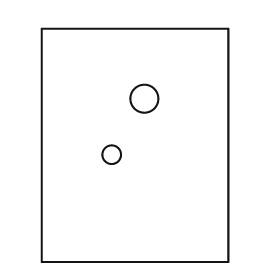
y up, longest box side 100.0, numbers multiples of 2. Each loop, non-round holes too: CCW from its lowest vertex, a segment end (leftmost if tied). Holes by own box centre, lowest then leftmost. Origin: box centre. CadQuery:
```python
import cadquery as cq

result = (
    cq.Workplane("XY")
    .moveTo(-40.0, -50.0)
    .lineTo(40.0, -50.0)
    .lineTo(40.0, 50.0)
    .lineTo(-40.0, 50.0)
    .close()
    .moveTo(-10.0, -4.0)
    .circle(4.0)
    .moveTo(4.0, 20.0)
    .circle(6.0)
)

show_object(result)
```